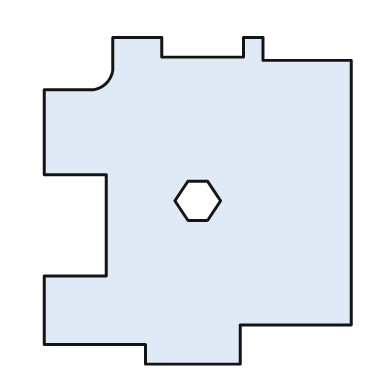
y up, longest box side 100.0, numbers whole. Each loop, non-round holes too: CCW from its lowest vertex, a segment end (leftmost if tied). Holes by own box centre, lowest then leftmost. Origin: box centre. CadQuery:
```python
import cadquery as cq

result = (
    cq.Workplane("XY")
    .moveTo(-16.0, -50.0)
    .lineTo(13.0, -50.0)
    .lineTo(13.0, -38.0)
    .lineTo(47.0, -38.0)
    .lineTo(47.0, 43.0)
    .lineTo(20.0, 43.0)
    .lineTo(20.0, 50.0)
    .lineTo(14.0, 50.0)
    .lineTo(14.0, 44.0)
    .lineTo(-11.0, 44.0)
    .lineTo(-11.0, 50.0)
    .lineTo(-26.0, 50.0)
    .lineTo(-26.0, 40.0)
    .threePointArc((-28.0, 36.0), (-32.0, 34.0))
    .lineTo(-47.0, 34.0)
    .lineTo(-47.0, 8.0)
    .lineTo(-28.0, 8.0)
    .lineTo(-28.0, -23.0)
    .lineTo(-47.0, -23.0)
    .lineTo(-47.0, -44.0)
    .lineTo(-16.0, -44.0)
    .close()
    .moveTo(-3.0, -6.0)
    .lineTo(3.0, -6.0)
    .lineTo(7.0, 0.0)
    .lineTo(3.0, 6.0)
    .lineTo(-3.0, 6.0)
    .lineTo(-7.0, 0.0)
    .close()
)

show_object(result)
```